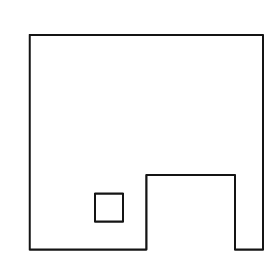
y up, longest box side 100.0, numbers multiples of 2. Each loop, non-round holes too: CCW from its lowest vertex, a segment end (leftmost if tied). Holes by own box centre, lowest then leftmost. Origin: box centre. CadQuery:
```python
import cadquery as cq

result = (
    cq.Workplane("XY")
    .moveTo(-50.0, -46.0)
    .lineTo(0.0, -46.0)
    .lineTo(0.0, -14.0)
    .lineTo(38.0, -14.0)
    .lineTo(38.0, -46.0)
    .lineTo(50.0, -46.0)
    .lineTo(50.0, 46.0)
    .lineTo(-50.0, 46.0)
    .close()
    .moveTo(-22.0, -34.0)
    .lineTo(-10.0, -34.0)
    .lineTo(-10.0, -22.0)
    .lineTo(-22.0, -22.0)
    .close()
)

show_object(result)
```